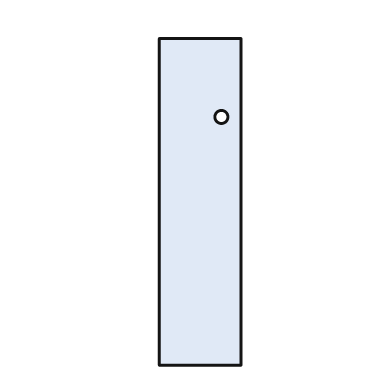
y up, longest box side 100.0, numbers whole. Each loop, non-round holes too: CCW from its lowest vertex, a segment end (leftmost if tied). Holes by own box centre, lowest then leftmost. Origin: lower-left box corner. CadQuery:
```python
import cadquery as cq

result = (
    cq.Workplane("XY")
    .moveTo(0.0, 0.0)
    .lineTo(25.0, 0.0)
    .lineTo(25.0, 100.0)
    .lineTo(0.0, 100.0)
    .close()
    .moveTo(19.0, 76.0)
    .circle(2.0)
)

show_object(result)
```